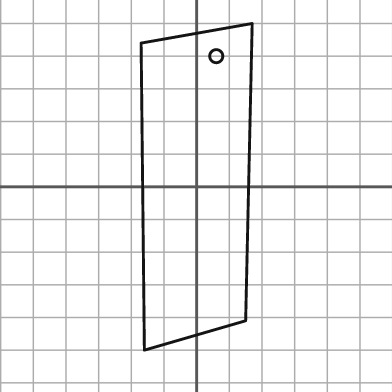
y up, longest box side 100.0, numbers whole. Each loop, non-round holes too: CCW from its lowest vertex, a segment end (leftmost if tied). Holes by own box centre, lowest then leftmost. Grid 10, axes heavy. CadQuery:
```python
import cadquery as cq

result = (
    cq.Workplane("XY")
    .moveTo(-16.0, -50.0)
    .lineTo(15.0, -41.0)
    .lineTo(17.0, 50.0)
    .lineTo(-17.0, 44.0)
    .close()
    .moveTo(6.0, 40.0)
    .circle(2.0)
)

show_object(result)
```